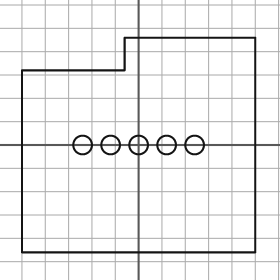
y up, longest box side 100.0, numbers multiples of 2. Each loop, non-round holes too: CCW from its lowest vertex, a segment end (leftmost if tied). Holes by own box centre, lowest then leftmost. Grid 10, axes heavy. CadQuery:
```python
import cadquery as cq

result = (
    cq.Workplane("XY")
    .moveTo(-50.0, -46.0)
    .lineTo(50.0, -46.0)
    .lineTo(50.0, 46.0)
    .lineTo(-6.0, 46.0)
    .lineTo(-6.0, 32.0)
    .lineTo(-50.0, 32.0)
    .close()
    .moveTo(-24.0, 0.0)
    .circle(4.0)
    .moveTo(-12.0, 0.0)
    .circle(4.0)
    .moveTo(0.0, 0.0)
    .circle(4.0)
    .moveTo(12.0, 0.0)
    .circle(4.0)
    .moveTo(24.0, 0.0)
    .circle(4.0)
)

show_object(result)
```